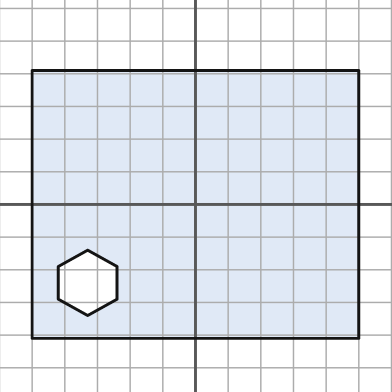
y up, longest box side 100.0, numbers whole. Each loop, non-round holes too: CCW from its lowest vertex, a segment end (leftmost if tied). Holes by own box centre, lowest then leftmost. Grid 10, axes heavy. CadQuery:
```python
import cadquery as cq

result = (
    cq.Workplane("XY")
    .moveTo(-50.0, -41.0)
    .lineTo(50.0, -41.0)
    .lineTo(50.0, 41.0)
    .lineTo(-50.0, 41.0)
    .close()
    .moveTo(-33.0, -34.0)
    .lineTo(-24.0, -29.0)
    .lineTo(-24.0, -19.0)
    .lineTo(-33.0, -14.0)
    .lineTo(-42.0, -19.0)
    .lineTo(-42.0, -29.0)
    .close()
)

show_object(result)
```